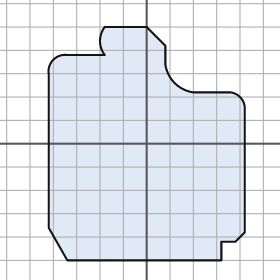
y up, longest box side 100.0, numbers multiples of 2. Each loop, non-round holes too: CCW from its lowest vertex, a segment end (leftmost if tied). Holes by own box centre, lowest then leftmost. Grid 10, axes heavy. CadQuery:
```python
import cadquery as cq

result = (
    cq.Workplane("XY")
    .moveTo(-34.0, -50.0)
    .lineTo(32.0, -50.0)
    .lineTo(32.0, -42.0)
    .lineTo(38.0, -42.0)
    .lineTo(42.0, -38.0)
    .lineTo(42.0, 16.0)
    .threePointArc((40.0, 20.0), (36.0, 22.0))
    .lineTo(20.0, 22.0)
    .threePointArc((12.0, 26.0), (8.0, 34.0))
    .lineTo(8.0, 42.0)
    .lineTo(0.0, 50.0)
    .lineTo(-18.0, 50.0)
    .threePointArc((-20.0, 44.0), (-18.0, 38.0))
    .lineTo(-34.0, 38.0)
    .threePointArc((-40.0, 36.0), (-42.0, 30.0))
    .lineTo(-42.0, -36.0)
    .close()
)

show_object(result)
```